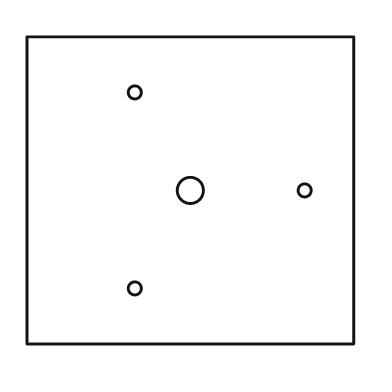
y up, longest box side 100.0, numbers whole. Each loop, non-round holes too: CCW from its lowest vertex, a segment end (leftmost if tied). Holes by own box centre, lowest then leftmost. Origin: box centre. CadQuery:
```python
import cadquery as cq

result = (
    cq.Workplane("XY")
    .moveTo(-50.0, -47.0)
    .lineTo(50.0, -47.0)
    .lineTo(50.0, 47.0)
    .lineTo(-50.0, 47.0)
    .close()
    .moveTo(-17.0, -30.0)
    .circle(2.0)
    .moveTo(0.0, 0.0)
    .circle(4.0)
    .moveTo(35.0, 0.0)
    .circle(2.0)
    .moveTo(-17.0, 30.0)
    .circle(2.0)
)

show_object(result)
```